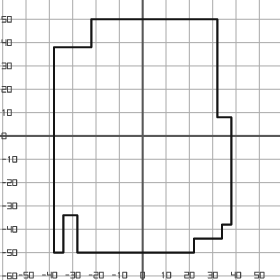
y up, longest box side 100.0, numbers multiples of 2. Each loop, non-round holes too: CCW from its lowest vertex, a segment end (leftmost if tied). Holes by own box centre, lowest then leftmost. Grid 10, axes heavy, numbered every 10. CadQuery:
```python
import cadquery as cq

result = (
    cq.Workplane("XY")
    .moveTo(-38.0, -50.0)
    .lineTo(-34.0, -50.0)
    .lineTo(-34.0, -34.0)
    .lineTo(-28.0, -34.0)
    .lineTo(-28.0, -50.0)
    .lineTo(22.0, -50.0)
    .lineTo(22.0, -44.0)
    .lineTo(34.0, -44.0)
    .lineTo(34.0, -38.0)
    .lineTo(38.0, -38.0)
    .lineTo(38.0, 8.0)
    .lineTo(32.0, 8.0)
    .lineTo(32.0, 50.0)
    .lineTo(-22.0, 50.0)
    .lineTo(-22.0, 38.0)
    .lineTo(-38.0, 38.0)
    .close()
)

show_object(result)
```